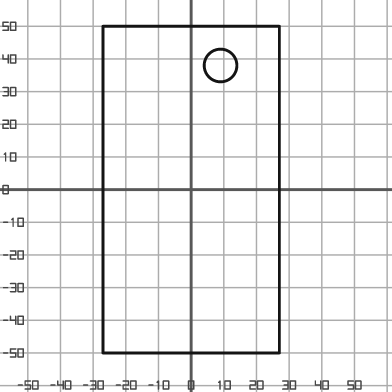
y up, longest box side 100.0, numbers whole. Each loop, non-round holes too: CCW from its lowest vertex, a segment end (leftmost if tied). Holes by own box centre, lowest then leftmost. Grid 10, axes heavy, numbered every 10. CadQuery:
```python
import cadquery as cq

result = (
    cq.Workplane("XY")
    .moveTo(-27.0, -50.0)
    .lineTo(27.0, -50.0)
    .lineTo(27.0, 50.0)
    .lineTo(-27.0, 50.0)
    .close()
    .moveTo(9.0, 38.0)
    .circle(5.0)
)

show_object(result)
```